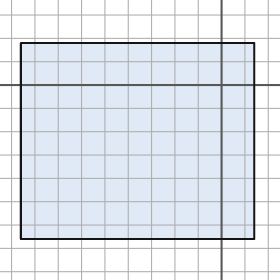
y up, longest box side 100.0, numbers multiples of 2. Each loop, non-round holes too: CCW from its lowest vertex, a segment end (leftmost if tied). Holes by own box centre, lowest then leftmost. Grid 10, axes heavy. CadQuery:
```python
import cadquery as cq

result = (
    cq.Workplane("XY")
    .moveTo(-86.0, -66.0)
    .lineTo(14.0, -66.0)
    .lineTo(14.0, 18.0)
    .lineTo(-86.0, 18.0)
    .close()
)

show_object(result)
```